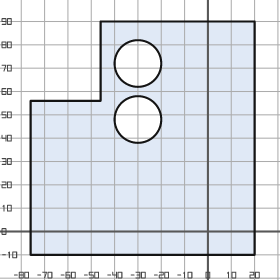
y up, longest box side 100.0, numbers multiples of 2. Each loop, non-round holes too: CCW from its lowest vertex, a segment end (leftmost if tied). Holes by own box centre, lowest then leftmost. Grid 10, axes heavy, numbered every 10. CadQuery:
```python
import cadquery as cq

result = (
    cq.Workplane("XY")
    .moveTo(-76.0, -10.0)
    .lineTo(20.0, -10.0)
    .lineTo(20.0, 90.0)
    .lineTo(-46.0, 90.0)
    .lineTo(-46.0, 56.0)
    .lineTo(-76.0, 56.0)
    .close()
    .moveTo(-30.0, 48.0)
    .circle(10.0)
    .moveTo(-30.0, 72.0)
    .circle(10.0)
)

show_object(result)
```